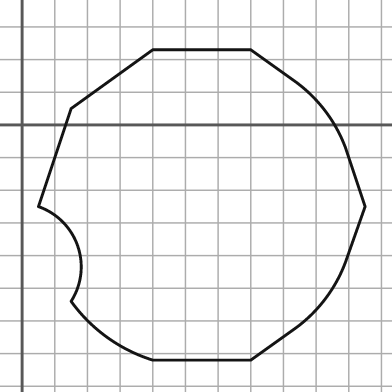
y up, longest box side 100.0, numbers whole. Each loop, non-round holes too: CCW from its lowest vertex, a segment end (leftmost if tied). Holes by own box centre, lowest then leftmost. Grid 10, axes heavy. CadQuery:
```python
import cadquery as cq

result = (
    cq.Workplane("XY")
    .moveTo(40.0, -72.0)
    .lineTo(70.0, -72.0)
    .lineTo(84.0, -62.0)
    .threePointArc((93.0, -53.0), (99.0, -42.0))
    .lineTo(105.0, -25.0)
    .lineTo(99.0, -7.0)
    .threePointArc((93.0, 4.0), (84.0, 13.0))
    .lineTo(70.0, 23.0)
    .lineTo(40.0, 23.0)
    .lineTo(15.0, 5.0)
    .lineTo(5.0, -25.0)
    .threePointArc((17.0, -37.0), (15.0, -54.0))
    .threePointArc((26.0, -65.0), (40.0, -72.0))
    .close()
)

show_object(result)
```